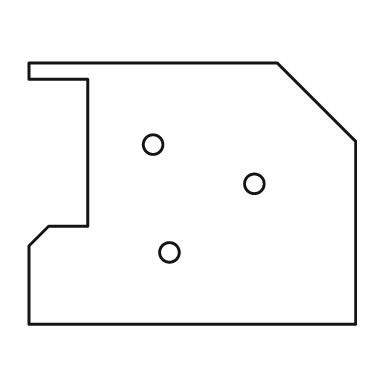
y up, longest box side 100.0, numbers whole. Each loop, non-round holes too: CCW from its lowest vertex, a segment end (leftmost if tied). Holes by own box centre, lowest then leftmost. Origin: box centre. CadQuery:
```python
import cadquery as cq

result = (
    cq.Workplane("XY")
    .moveTo(-50.0, -40.0)
    .lineTo(50.0, -40.0)
    .lineTo(50.0, 16.0)
    .lineTo(26.0, 40.0)
    .lineTo(-50.0, 40.0)
    .lineTo(-50.0, 35.0)
    .lineTo(-32.0, 35.0)
    .lineTo(-32.0, -10.0)
    .lineTo(-44.0, -10.0)
    .lineTo(-50.0, -16.0)
    .close()
    .moveTo(-7.0, -18.0)
    .circle(3.0)
    .moveTo(19.0, 3.0)
    .circle(3.0)
    .moveTo(-12.0, 15.0)
    .circle(3.0)
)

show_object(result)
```